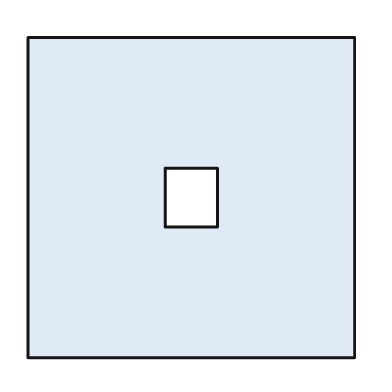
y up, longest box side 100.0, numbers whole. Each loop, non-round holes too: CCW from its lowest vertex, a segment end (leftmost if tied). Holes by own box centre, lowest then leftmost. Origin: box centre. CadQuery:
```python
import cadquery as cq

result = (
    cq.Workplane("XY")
    .moveTo(-50.0, -49.0)
    .lineTo(50.0, -49.0)
    .lineTo(50.0, 49.0)
    .lineTo(-50.0, 49.0)
    .close()
    .moveTo(-8.0, -9.0)
    .lineTo(8.0, -9.0)
    .lineTo(8.0, 9.0)
    .lineTo(-8.0, 9.0)
    .close()
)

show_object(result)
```